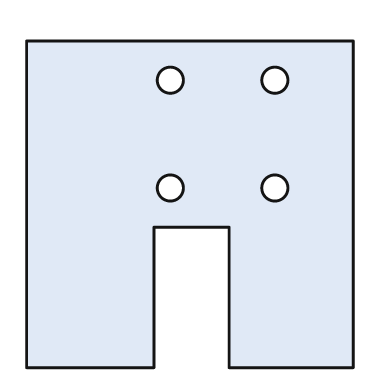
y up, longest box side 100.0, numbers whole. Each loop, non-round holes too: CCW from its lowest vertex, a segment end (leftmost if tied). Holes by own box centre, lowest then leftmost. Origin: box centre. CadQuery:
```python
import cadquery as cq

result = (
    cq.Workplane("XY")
    .moveTo(-50.0, -50.0)
    .lineTo(-11.0, -50.0)
    .lineTo(-11.0, -7.0)
    .lineTo(12.0, -7.0)
    .lineTo(12.0, -50.0)
    .lineTo(50.0, -50.0)
    .lineTo(50.0, 50.0)
    .lineTo(-50.0, 50.0)
    .close()
    .moveTo(-6.0, 5.0)
    .circle(4.0)
    .moveTo(26.0, 5.0)
    .circle(4.0)
    .moveTo(-6.0, 38.0)
    .circle(4.0)
    .moveTo(26.0, 38.0)
    .circle(4.0)
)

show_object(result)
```